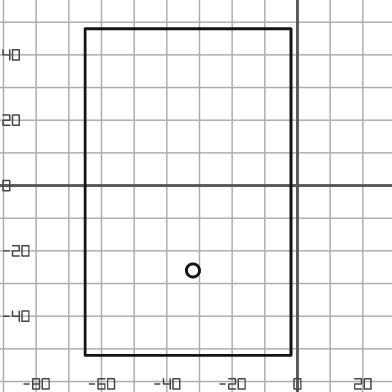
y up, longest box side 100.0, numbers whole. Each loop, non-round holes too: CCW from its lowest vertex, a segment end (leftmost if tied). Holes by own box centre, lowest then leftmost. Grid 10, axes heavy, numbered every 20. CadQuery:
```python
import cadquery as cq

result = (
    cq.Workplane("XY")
    .moveTo(-65.0, -52.0)
    .lineTo(-2.0, -52.0)
    .lineTo(-2.0, 48.0)
    .lineTo(-65.0, 48.0)
    .close()
    .moveTo(-32.0, -26.0)
    .circle(2.0)
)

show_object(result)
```